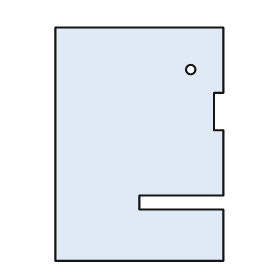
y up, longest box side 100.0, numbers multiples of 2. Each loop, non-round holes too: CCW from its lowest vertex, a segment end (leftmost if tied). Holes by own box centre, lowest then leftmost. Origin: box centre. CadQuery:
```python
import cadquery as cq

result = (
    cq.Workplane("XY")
    .moveTo(-36.0, -50.0)
    .lineTo(36.0, -50.0)
    .lineTo(36.0, -28.0)
    .lineTo(0.0, -28.0)
    .lineTo(0.0, -22.0)
    .lineTo(36.0, -22.0)
    .lineTo(36.0, 6.0)
    .lineTo(32.0, 6.0)
    .lineTo(32.0, 22.0)
    .lineTo(36.0, 22.0)
    .lineTo(36.0, 50.0)
    .lineTo(-36.0, 50.0)
    .close()
    .moveTo(22.0, 32.0)
    .circle(2.0)
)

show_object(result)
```